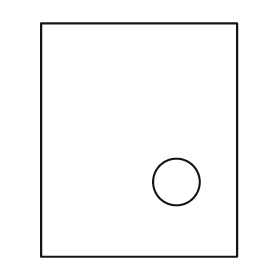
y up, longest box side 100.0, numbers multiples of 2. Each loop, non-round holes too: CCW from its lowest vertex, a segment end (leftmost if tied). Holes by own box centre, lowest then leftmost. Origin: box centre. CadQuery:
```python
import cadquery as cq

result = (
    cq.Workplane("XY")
    .moveTo(-42.0, -50.0)
    .lineTo(42.0, -50.0)
    .lineTo(42.0, 50.0)
    .lineTo(-42.0, 50.0)
    .close()
    .moveTo(16.0, -18.0)
    .circle(10.0)
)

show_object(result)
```